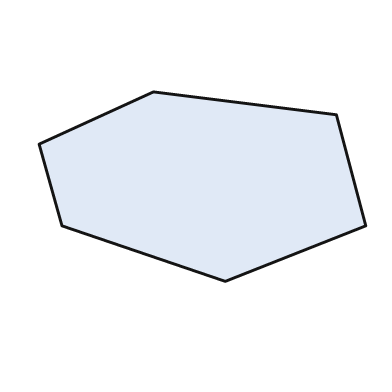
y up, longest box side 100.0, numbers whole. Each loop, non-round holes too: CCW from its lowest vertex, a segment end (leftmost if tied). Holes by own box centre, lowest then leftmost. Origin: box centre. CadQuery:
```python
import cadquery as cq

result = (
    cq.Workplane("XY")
    .moveTo(7.0, -29.0)
    .lineTo(50.0, -12.0)
    .lineTo(41.0, 22.0)
    .lineTo(-15.0, 29.0)
    .lineTo(-50.0, 13.0)
    .lineTo(-43.0, -12.0)
    .close()
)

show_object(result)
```